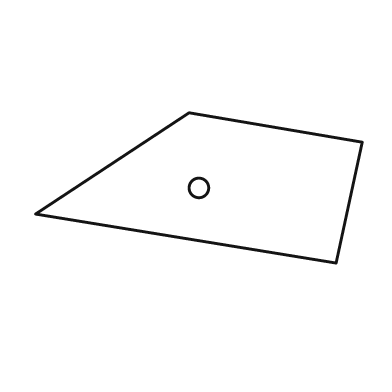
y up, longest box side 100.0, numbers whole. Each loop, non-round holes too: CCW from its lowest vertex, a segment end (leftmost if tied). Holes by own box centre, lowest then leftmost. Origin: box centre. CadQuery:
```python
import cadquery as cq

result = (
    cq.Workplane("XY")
    .moveTo(42.0, -23.0)
    .lineTo(50.0, 14.0)
    .lineTo(-3.0, 23.0)
    .lineTo(-50.0, -8.0)
    .close()
    .moveTo(0.0, 0.0)
    .circle(3.0)
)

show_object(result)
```